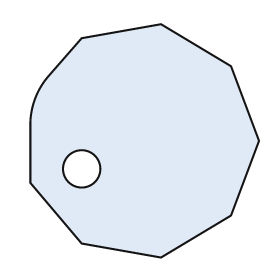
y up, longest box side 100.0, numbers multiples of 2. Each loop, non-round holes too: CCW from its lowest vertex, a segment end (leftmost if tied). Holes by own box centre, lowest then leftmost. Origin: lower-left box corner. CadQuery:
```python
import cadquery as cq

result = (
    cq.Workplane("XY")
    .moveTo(56.0, 0.0)
    .lineTo(86.0, 18.0)
    .lineTo(98.0, 50.0)
    .lineTo(86.0, 82.0)
    .lineTo(56.0, 100.0)
    .lineTo(22.0, 94.0)
    .lineTo(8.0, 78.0)
    .threePointArc((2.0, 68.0), (0.0, 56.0))
    .lineTo(0.0, 32.0)
    .lineTo(22.0, 6.0)
    .close()
    .moveTo(22.0, 38.0)
    .circle(8.0)
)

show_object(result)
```